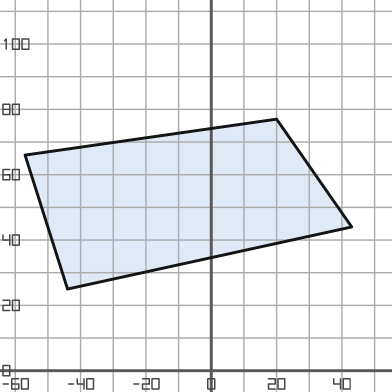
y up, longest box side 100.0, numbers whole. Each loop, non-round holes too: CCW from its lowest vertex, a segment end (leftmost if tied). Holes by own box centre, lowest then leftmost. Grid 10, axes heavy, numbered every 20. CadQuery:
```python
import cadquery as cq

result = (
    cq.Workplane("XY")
    .moveTo(-44.0, 25.0)
    .lineTo(43.0, 44.0)
    .lineTo(20.0, 77.0)
    .lineTo(-57.0, 66.0)
    .close()
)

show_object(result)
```